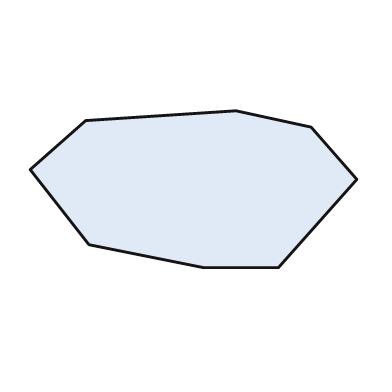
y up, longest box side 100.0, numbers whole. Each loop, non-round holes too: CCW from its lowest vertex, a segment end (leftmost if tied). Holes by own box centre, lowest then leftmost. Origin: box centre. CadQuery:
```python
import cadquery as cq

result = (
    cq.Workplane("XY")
    .moveTo(3.0, -24.0)
    .lineTo(26.0, -24.0)
    .lineTo(50.0, 3.0)
    .lineTo(36.0, 19.0)
    .lineTo(13.0, 24.0)
    .lineTo(-33.0, 21.0)
    .lineTo(-50.0, 6.0)
    .lineTo(-32.0, -17.0)
    .close()
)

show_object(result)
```